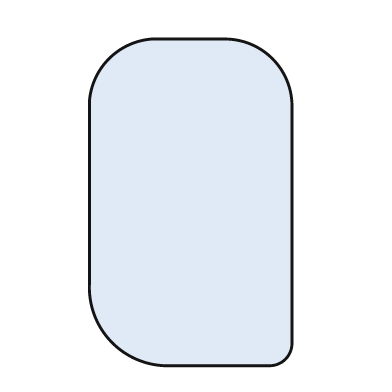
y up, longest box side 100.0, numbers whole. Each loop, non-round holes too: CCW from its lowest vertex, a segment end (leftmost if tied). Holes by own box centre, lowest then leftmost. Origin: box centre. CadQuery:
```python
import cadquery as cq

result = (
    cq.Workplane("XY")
    .moveTo(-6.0, -50.0)
    .lineTo(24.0, -50.0)
    .threePointArc((29.0, -48.0), (31.0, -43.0))
    .lineTo(31.0, 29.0)
    .threePointArc((25.0, 44.0), (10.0, 50.0))
    .lineTo(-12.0, 50.0)
    .threePointArc((-25.0, 44.0), (-31.0, 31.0))
    .lineTo(-31.0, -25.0)
    .threePointArc((-24.0, -43.0), (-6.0, -50.0))
    .close()
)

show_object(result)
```